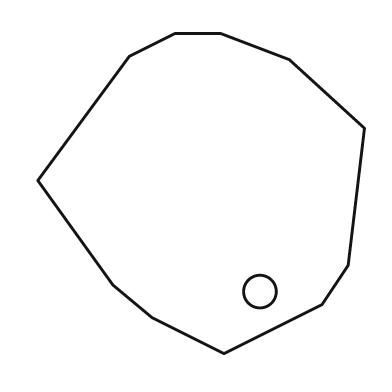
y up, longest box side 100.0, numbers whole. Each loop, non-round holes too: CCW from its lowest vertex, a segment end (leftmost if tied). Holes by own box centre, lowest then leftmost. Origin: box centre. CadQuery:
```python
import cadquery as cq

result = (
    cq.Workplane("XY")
    .moveTo(7.0, -49.0)
    .lineTo(37.0, -34.0)
    .lineTo(45.0, -22.0)
    .lineTo(50.0, 20.0)
    .lineTo(27.0, 41.0)
    .lineTo(6.0, 49.0)
    .lineTo(-8.0, 49.0)
    .lineTo(-22.0, 42.0)
    .lineTo(-50.0, 4.0)
    .lineTo(-27.0, -28.0)
    .lineTo(-15.0, -38.0)
    .close()
    .moveTo(18.0, -30.0)
    .circle(5.0)
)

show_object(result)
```